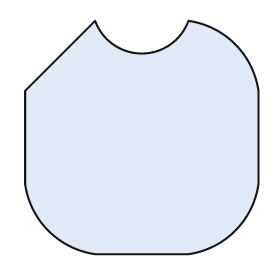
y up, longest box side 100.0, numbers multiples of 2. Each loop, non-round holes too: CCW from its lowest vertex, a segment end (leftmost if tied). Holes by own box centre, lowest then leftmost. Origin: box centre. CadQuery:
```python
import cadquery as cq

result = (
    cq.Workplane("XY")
    .moveTo(-20.0, -50.0)
    .lineTo(20.0, -50.0)
    .threePointArc((40.0, -40.0), (50.0, -20.0))
    .lineTo(50.0, 20.0)
    .threePointArc((40.0, 40.0), (20.0, 50.0))
    .threePointArc((0.0, 36.0), (-20.0, 50.0))
    .lineTo(-50.0, 20.0)
    .lineTo(-50.0, -20.0)
    .threePointArc((-40.0, -40.0), (-20.0, -50.0))
    .close()
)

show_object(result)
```